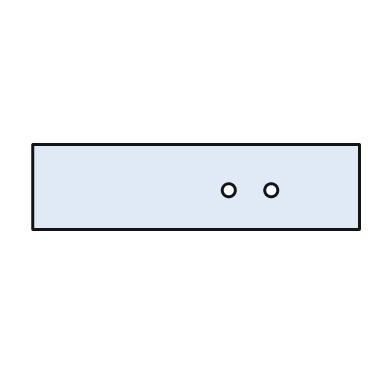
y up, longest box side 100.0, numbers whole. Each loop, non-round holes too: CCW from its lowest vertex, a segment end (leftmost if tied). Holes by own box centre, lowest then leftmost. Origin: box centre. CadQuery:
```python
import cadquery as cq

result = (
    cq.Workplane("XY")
    .moveTo(-50.0, -13.0)
    .lineTo(50.0, -13.0)
    .lineTo(50.0, 13.0)
    .lineTo(-50.0, 13.0)
    .close()
    .moveTo(10.0, -1.0)
    .circle(2.0)
    .moveTo(23.0, -1.0)
    .circle(2.0)
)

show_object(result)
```